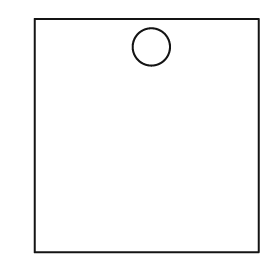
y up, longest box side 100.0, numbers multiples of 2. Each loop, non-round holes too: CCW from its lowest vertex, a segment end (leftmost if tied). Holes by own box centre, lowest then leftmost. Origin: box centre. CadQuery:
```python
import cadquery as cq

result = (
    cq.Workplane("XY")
    .moveTo(-48.0, -50.0)
    .lineTo(48.0, -50.0)
    .lineTo(48.0, 50.0)
    .lineTo(-48.0, 50.0)
    .close()
    .moveTo(2.0, 38.0)
    .circle(8.0)
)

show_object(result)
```